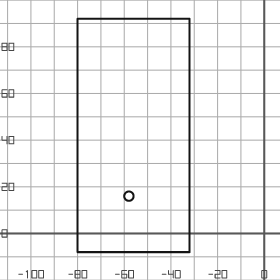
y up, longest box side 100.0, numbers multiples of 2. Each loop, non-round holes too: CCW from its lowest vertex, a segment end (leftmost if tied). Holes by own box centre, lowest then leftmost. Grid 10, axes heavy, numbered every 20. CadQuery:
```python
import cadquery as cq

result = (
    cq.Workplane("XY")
    .moveTo(-80.0, -8.0)
    .lineTo(-32.0, -8.0)
    .lineTo(-32.0, 92.0)
    .lineTo(-80.0, 92.0)
    .close()
    .moveTo(-58.0, 16.0)
    .circle(2.0)
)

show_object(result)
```